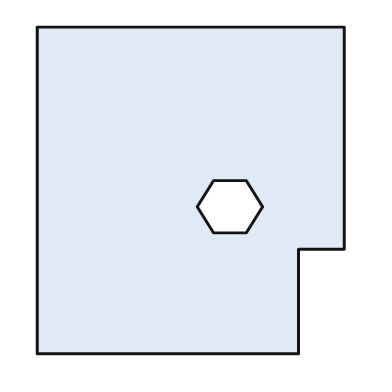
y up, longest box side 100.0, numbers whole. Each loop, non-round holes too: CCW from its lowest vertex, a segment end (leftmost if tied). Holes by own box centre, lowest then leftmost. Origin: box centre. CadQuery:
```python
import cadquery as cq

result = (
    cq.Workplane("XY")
    .moveTo(-47.0, -50.0)
    .lineTo(33.0, -50.0)
    .lineTo(33.0, -18.0)
    .lineTo(47.0, -18.0)
    .lineTo(47.0, 50.0)
    .lineTo(-47.0, 50.0)
    .close()
    .moveTo(7.0, -13.0)
    .lineTo(17.0, -13.0)
    .lineTo(22.0, -5.0)
    .lineTo(17.0, 3.0)
    .lineTo(7.0, 3.0)
    .lineTo(2.0, -5.0)
    .close()
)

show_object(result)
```